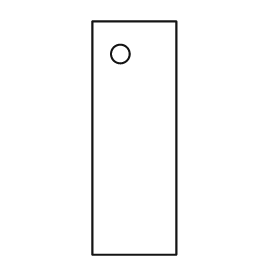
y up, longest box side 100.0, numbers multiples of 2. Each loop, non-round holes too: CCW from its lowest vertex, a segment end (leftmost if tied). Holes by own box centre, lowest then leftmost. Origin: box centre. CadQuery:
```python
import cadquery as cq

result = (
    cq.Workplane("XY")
    .moveTo(-18.0, -50.0)
    .lineTo(18.0, -50.0)
    .lineTo(18.0, 50.0)
    .lineTo(-18.0, 50.0)
    .close()
    .moveTo(-6.0, 36.0)
    .circle(4.0)
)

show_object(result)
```